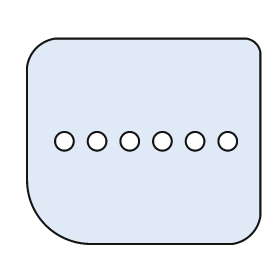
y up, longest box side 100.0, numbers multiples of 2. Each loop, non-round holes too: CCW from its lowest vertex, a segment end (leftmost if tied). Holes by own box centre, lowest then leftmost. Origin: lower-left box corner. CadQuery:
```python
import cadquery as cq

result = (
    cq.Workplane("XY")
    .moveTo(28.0, 0.0)
    .lineTo(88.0, 0.0)
    .threePointArc((96.0, 4.0), (100.0, 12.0))
    .lineTo(100.0, 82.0)
    .threePointArc((98.0, 86.0), (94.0, 88.0))
    .lineTo(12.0, 88.0)
    .threePointArc((4.0, 84.0), (0.0, 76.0))
    .lineTo(0.0, 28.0)
    .threePointArc((8.0, 8.0), (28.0, 0.0))
    .close()
    .moveTo(16.0, 44.0)
    .circle(4.0)
    .moveTo(30.0, 44.0)
    .circle(4.0)
    .moveTo(44.0, 44.0)
    .circle(4.0)
    .moveTo(58.0, 44.0)
    .circle(4.0)
    .moveTo(72.0, 44.0)
    .circle(4.0)
    .moveTo(86.0, 44.0)
    .circle(4.0)
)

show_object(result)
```